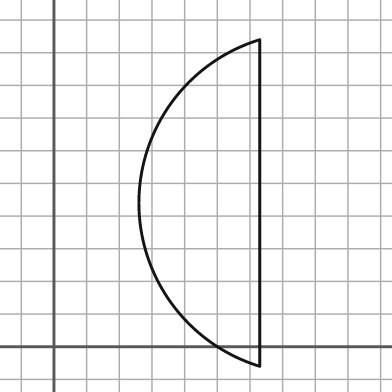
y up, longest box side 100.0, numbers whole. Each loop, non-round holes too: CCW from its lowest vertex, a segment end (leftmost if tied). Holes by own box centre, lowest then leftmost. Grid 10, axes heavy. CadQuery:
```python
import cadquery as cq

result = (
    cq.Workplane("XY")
    .moveTo(63.0, -6.0)
    .lineTo(63.0, 94.0)
    .threePointArc((26.0, 44.0), (63.0, -6.0))
    .close()
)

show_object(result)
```